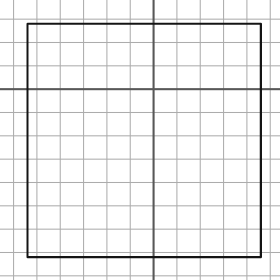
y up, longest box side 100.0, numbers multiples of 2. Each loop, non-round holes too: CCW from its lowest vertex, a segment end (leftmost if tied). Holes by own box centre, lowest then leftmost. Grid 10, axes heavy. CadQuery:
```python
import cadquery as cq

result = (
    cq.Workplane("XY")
    .moveTo(-54.0, -72.0)
    .lineTo(46.0, -72.0)
    .lineTo(46.0, 28.0)
    .lineTo(-54.0, 28.0)
    .close()
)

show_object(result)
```